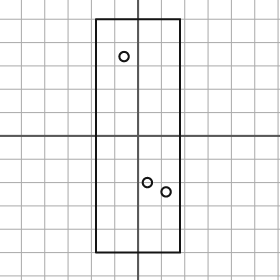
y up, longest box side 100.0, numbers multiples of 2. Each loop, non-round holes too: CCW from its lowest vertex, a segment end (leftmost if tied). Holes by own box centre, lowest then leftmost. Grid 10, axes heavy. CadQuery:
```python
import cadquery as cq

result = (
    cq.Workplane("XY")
    .moveTo(-18.0, -50.0)
    .lineTo(18.0, -50.0)
    .lineTo(18.0, 50.0)
    .lineTo(-18.0, 50.0)
    .close()
    .moveTo(12.0, -24.0)
    .circle(2.0)
    .moveTo(4.0, -20.0)
    .circle(2.0)
    .moveTo(-6.0, 34.0)
    .circle(2.0)
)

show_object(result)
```